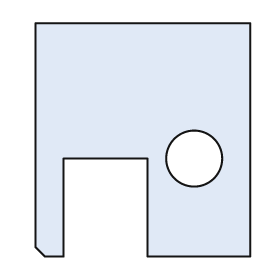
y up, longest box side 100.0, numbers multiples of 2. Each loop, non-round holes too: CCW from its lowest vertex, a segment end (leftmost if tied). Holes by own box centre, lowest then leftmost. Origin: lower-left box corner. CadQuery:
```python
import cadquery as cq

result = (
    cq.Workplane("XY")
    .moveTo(4.0, 0.0)
    .lineTo(12.0, 0.0)
    .lineTo(12.0, 42.0)
    .lineTo(48.0, 42.0)
    .lineTo(48.0, 0.0)
    .lineTo(92.0, 0.0)
    .lineTo(92.0, 100.0)
    .lineTo(0.0, 100.0)
    .lineTo(0.0, 4.0)
    .close()
    .moveTo(68.0, 42.0)
    .circle(12.0)
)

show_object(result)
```